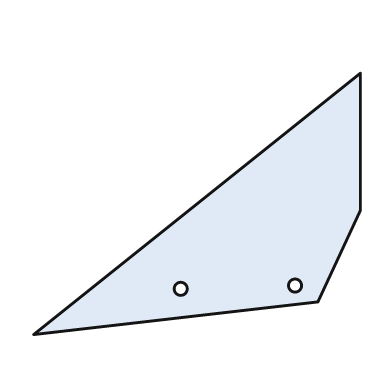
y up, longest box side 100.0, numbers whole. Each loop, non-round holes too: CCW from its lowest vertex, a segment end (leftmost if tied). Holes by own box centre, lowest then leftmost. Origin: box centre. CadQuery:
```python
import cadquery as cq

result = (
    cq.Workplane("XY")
    .moveTo(-50.0, -40.0)
    .lineTo(37.0, -30.0)
    .lineTo(50.0, -2.0)
    .lineTo(50.0, 40.0)
    .close()
    .moveTo(-5.0, -26.0)
    .circle(2.0)
    .moveTo(30.0, -25.0)
    .circle(2.0)
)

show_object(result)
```